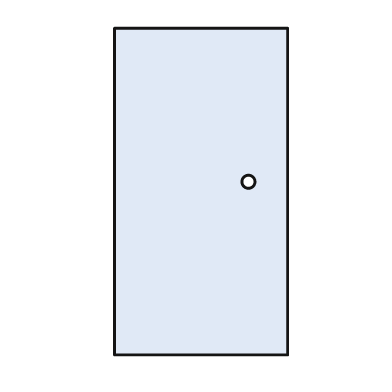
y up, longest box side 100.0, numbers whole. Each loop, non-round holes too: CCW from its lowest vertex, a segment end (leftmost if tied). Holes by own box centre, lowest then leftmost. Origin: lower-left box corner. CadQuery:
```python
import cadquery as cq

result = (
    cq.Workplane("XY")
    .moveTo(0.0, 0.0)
    .lineTo(53.0, 0.0)
    .lineTo(53.0, 100.0)
    .lineTo(0.0, 100.0)
    .close()
    .moveTo(41.0, 53.0)
    .circle(2.0)
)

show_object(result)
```